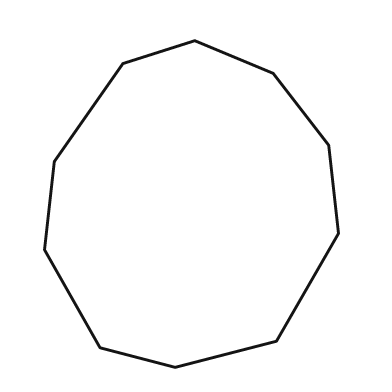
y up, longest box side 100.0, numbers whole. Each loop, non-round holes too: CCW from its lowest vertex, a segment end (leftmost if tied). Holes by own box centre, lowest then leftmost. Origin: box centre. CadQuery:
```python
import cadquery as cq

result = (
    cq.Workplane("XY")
    .moveTo(-5.0, -50.0)
    .lineTo(26.0, -42.0)
    .lineTo(45.0, -9.0)
    .lineTo(42.0, 18.0)
    .lineTo(25.0, 40.0)
    .lineTo(1.0, 50.0)
    .lineTo(-21.0, 43.0)
    .lineTo(-42.0, 13.0)
    .lineTo(-45.0, -14.0)
    .lineTo(-28.0, -44.0)
    .close()
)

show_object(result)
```